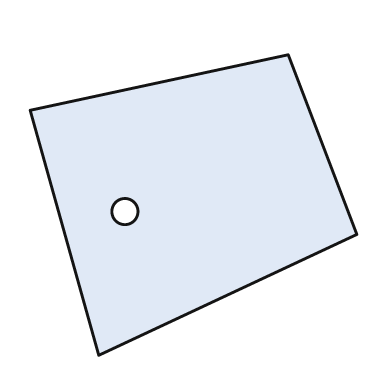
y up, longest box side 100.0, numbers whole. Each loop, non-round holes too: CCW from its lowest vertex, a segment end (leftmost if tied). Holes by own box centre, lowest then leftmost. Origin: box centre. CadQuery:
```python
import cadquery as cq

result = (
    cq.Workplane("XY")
    .moveTo(-29.0, -46.0)
    .lineTo(50.0, -9.0)
    .lineTo(29.0, 46.0)
    .lineTo(-50.0, 29.0)
    .close()
    .moveTo(-21.0, -2.0)
    .circle(4.0)
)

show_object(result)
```